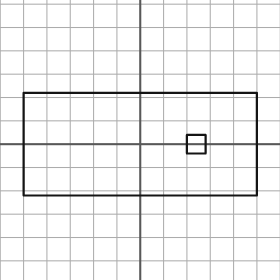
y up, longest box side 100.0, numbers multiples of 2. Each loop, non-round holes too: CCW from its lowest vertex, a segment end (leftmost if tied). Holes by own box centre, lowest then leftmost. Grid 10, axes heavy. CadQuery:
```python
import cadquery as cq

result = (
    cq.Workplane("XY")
    .moveTo(-50.0, -22.0)
    .lineTo(50.0, -22.0)
    .lineTo(50.0, 22.0)
    .lineTo(-50.0, 22.0)
    .close()
    .moveTo(20.0, -4.0)
    .lineTo(28.0, -4.0)
    .lineTo(28.0, 4.0)
    .lineTo(20.0, 4.0)
    .close()
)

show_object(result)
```